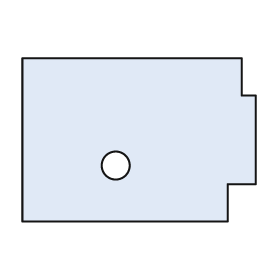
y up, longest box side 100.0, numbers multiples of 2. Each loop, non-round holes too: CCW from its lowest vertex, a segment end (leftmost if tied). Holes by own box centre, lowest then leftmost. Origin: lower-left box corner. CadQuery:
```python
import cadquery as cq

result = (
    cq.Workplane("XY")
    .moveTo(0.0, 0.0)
    .lineTo(88.0, 0.0)
    .lineTo(88.0, 16.0)
    .lineTo(100.0, 16.0)
    .lineTo(100.0, 54.0)
    .lineTo(94.0, 54.0)
    .lineTo(94.0, 70.0)
    .lineTo(0.0, 70.0)
    .close()
    .moveTo(40.0, 24.0)
    .circle(6.0)
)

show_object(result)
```